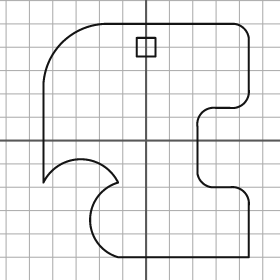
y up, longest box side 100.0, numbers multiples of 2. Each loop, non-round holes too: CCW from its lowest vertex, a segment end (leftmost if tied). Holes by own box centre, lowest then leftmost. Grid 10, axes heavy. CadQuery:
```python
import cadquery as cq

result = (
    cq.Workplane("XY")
    .moveTo(-12.0, -50.0)
    .lineTo(44.0, -50.0)
    .lineTo(44.0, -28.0)
    .threePointArc((42.0, -22.0), (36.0, -20.0))
    .lineTo(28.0, -20.0)
    .threePointArc((24.0, -18.0), (22.0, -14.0))
    .lineTo(22.0, 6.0)
    .threePointArc((24.0, 12.0), (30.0, 14.0))
    .lineTo(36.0, 14.0)
    .threePointArc((42.0, 16.0), (44.0, 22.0))
    .lineTo(44.0, 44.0)
    .threePointArc((42.0, 48.0), (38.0, 50.0))
    .lineTo(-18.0, 50.0)
    .threePointArc((-36.0, 42.0), (-44.0, 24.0))
    .lineTo(-44.0, -18.0)
    .threePointArc((-28.0, -8.0), (-12.0, -18.0))
    .threePointArc((-24.0, -34.0), (-12.0, -50.0))
    .close()
    .moveTo(-4.0, 36.0)
    .lineTo(4.0, 36.0)
    .lineTo(4.0, 44.0)
    .lineTo(-4.0, 44.0)
    .close()
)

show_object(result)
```